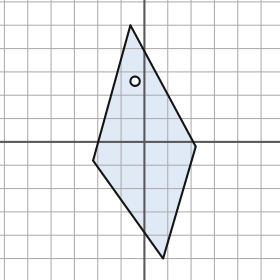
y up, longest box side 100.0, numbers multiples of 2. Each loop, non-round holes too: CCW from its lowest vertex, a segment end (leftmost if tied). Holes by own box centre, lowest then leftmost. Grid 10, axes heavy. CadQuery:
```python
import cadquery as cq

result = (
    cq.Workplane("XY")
    .moveTo(8.0, -50.0)
    .lineTo(22.0, -2.0)
    .lineTo(-6.0, 50.0)
    .lineTo(-22.0, -8.0)
    .close()
    .moveTo(-4.0, 26.0)
    .circle(2.0)
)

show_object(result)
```